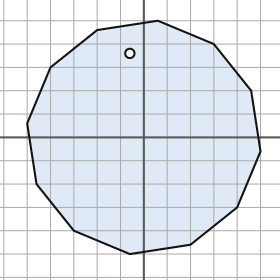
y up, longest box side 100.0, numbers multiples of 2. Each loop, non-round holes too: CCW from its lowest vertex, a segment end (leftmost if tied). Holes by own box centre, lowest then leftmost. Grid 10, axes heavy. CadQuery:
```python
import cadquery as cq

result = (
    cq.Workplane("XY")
    .moveTo(-6.0, -50.0)
    .lineTo(20.0, -46.0)
    .lineTo(40.0, -30.0)
    .lineTo(50.0, -6.0)
    .lineTo(46.0, 20.0)
    .lineTo(30.0, 40.0)
    .lineTo(6.0, 50.0)
    .lineTo(-20.0, 46.0)
    .lineTo(-40.0, 30.0)
    .lineTo(-50.0, 6.0)
    .lineTo(-46.0, -20.0)
    .lineTo(-30.0, -40.0)
    .close()
    .moveTo(-6.0, 36.0)
    .circle(2.0)
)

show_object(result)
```